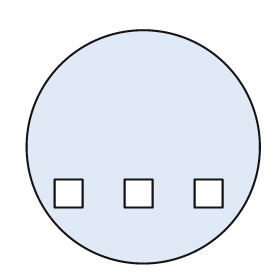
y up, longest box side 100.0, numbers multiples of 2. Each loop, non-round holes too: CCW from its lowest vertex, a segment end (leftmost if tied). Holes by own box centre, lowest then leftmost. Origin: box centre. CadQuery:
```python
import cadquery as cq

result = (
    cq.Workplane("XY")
    .moveTo(0.0, 0.0)
    .circle(50.0)
    .moveTo(-38.0, -26.0)
    .lineTo(-26.0, -26.0)
    .lineTo(-26.0, -14.0)
    .lineTo(-38.0, -14.0)
    .close()
    .moveTo(-8.0, -26.0)
    .lineTo(4.0, -26.0)
    .lineTo(4.0, -14.0)
    .lineTo(-8.0, -14.0)
    .close()
    .moveTo(22.0, -26.0)
    .lineTo(34.0, -26.0)
    .lineTo(34.0, -14.0)
    .lineTo(22.0, -14.0)
    .close()
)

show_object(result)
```